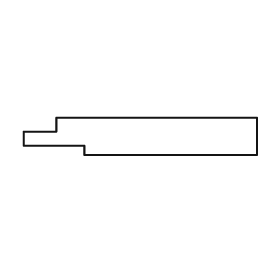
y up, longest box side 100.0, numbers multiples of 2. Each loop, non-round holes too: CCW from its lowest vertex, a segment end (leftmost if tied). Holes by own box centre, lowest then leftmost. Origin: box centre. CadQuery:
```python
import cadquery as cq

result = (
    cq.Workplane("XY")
    .moveTo(-24.0, -8.0)
    .lineTo(50.0, -8.0)
    .lineTo(50.0, 8.0)
    .lineTo(-36.0, 8.0)
    .lineTo(-36.0, 2.0)
    .lineTo(-50.0, 2.0)
    .lineTo(-50.0, -4.0)
    .lineTo(-24.0, -4.0)
    .close()
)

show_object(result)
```